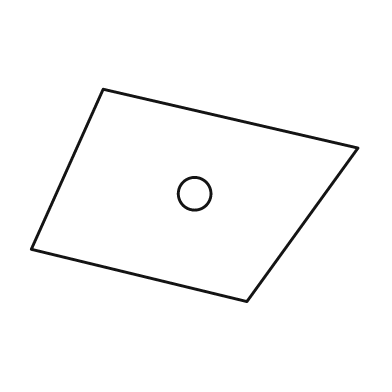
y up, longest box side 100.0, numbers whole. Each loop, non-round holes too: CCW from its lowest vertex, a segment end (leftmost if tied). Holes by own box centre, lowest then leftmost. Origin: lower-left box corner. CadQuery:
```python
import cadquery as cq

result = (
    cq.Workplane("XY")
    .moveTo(66.0, 0.0)
    .lineTo(100.0, 47.0)
    .lineTo(22.0, 65.0)
    .lineTo(0.0, 16.0)
    .close()
    .moveTo(50.0, 33.0)
    .circle(5.0)
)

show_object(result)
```